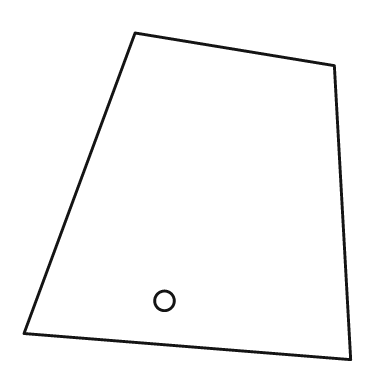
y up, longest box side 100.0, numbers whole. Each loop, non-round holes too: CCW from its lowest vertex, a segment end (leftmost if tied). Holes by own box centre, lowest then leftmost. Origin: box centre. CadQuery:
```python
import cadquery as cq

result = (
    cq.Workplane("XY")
    .moveTo(50.0, -50.0)
    .lineTo(45.0, 40.0)
    .lineTo(-16.0, 50.0)
    .lineTo(-50.0, -42.0)
    .close()
    .moveTo(-7.0, -32.0)
    .circle(3.0)
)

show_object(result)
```